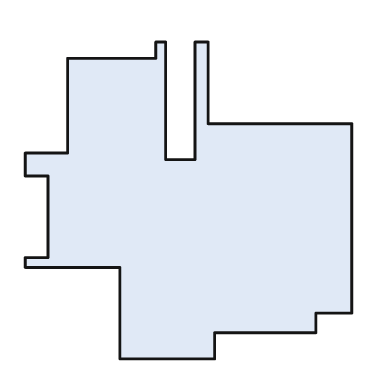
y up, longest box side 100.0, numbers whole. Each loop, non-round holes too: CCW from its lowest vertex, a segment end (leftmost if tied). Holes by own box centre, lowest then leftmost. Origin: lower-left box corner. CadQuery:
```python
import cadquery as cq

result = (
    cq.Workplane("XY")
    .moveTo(29.0, 0.0)
    .lineTo(58.0, 0.0)
    .lineTo(58.0, 8.0)
    .lineTo(89.0, 8.0)
    .lineTo(89.0, 14.0)
    .lineTo(100.0, 14.0)
    .lineTo(100.0, 72.0)
    .lineTo(56.0, 72.0)
    .lineTo(56.0, 97.0)
    .lineTo(52.0, 97.0)
    .lineTo(52.0, 61.0)
    .lineTo(43.0, 61.0)
    .lineTo(43.0, 97.0)
    .lineTo(40.0, 97.0)
    .lineTo(40.0, 92.0)
    .lineTo(13.0, 92.0)
    .lineTo(13.0, 63.0)
    .lineTo(0.0, 63.0)
    .lineTo(0.0, 56.0)
    .lineTo(7.0, 56.0)
    .lineTo(7.0, 31.0)
    .lineTo(0.0, 31.0)
    .lineTo(0.0, 28.0)
    .lineTo(29.0, 28.0)
    .close()
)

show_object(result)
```